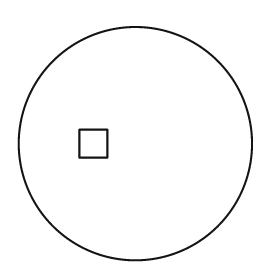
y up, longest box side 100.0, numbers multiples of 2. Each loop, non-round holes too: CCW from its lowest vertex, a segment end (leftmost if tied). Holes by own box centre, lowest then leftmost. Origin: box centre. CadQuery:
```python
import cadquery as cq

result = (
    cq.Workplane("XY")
    .moveTo(0.0, 0.0)
    .circle(50.0)
    .moveTo(-24.0, -6.0)
    .lineTo(-12.0, -6.0)
    .lineTo(-12.0, 6.0)
    .lineTo(-24.0, 6.0)
    .close()
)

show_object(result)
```